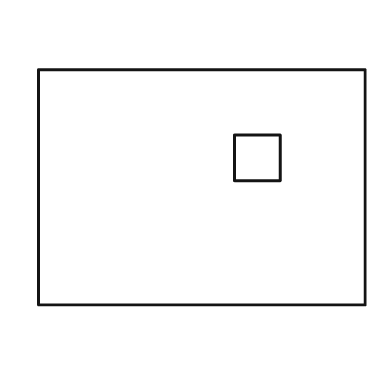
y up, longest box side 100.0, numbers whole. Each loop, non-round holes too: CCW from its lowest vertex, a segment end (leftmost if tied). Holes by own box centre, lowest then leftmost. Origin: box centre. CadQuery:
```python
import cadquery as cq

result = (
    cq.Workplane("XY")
    .moveTo(-50.0, -36.0)
    .lineTo(50.0, -36.0)
    .lineTo(50.0, 36.0)
    .lineTo(-50.0, 36.0)
    .close()
    .moveTo(10.0, 2.0)
    .lineTo(24.0, 2.0)
    .lineTo(24.0, 16.0)
    .lineTo(10.0, 16.0)
    .close()
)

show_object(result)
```